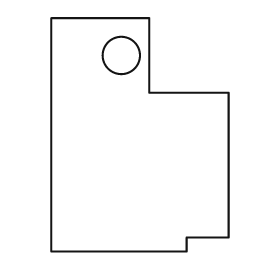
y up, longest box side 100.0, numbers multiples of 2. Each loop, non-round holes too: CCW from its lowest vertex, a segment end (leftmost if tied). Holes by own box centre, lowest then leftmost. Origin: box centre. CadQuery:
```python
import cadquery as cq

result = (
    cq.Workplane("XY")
    .moveTo(-38.0, -50.0)
    .lineTo(20.0, -50.0)
    .lineTo(20.0, -44.0)
    .lineTo(38.0, -44.0)
    .lineTo(38.0, 18.0)
    .lineTo(4.0, 18.0)
    .lineTo(4.0, 50.0)
    .lineTo(-38.0, 50.0)
    .close()
    .moveTo(-8.0, 34.0)
    .circle(8.0)
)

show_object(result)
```